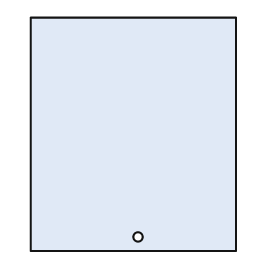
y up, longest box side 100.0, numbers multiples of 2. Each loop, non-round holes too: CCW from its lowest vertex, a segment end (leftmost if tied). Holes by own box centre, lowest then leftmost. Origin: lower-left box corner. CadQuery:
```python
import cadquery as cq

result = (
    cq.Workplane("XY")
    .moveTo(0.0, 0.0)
    .lineTo(88.0, 0.0)
    .lineTo(88.0, 100.0)
    .lineTo(0.0, 100.0)
    .close()
    .moveTo(46.0, 6.0)
    .circle(2.0)
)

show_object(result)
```